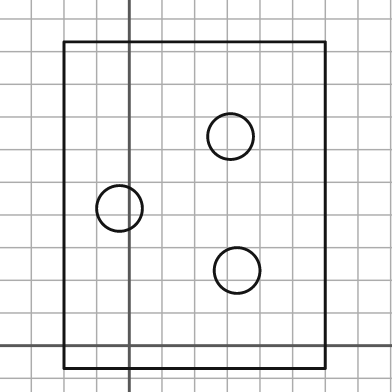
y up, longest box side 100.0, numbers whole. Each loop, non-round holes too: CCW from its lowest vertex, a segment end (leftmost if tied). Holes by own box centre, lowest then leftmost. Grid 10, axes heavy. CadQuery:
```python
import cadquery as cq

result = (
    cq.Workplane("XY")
    .moveTo(-20.0, -7.0)
    .lineTo(60.0, -7.0)
    .lineTo(60.0, 93.0)
    .lineTo(-20.0, 93.0)
    .close()
    .moveTo(33.0, 23.0)
    .circle(7.0)
    .moveTo(-3.0, 42.0)
    .circle(7.0)
    .moveTo(31.0, 64.0)
    .circle(7.0)
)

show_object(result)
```